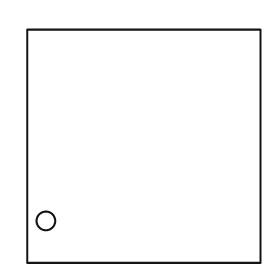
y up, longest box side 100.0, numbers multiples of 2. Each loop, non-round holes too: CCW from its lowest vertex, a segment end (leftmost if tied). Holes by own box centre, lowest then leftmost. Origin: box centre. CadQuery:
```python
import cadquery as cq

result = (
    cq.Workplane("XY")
    .moveTo(-50.0, -50.0)
    .lineTo(50.0, -50.0)
    .lineTo(50.0, 50.0)
    .lineTo(-50.0, 50.0)
    .close()
    .moveTo(-42.0, -32.0)
    .circle(4.0)
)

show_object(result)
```